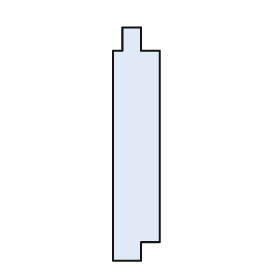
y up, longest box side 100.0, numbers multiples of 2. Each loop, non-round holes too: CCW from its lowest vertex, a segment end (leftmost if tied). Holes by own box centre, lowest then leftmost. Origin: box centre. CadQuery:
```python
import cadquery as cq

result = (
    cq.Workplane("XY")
    .moveTo(-10.0, -50.0)
    .lineTo(2.0, -50.0)
    .lineTo(2.0, -42.0)
    .lineTo(10.0, -42.0)
    .lineTo(10.0, 40.0)
    .lineTo(2.0, 40.0)
    .lineTo(2.0, 50.0)
    .lineTo(-6.0, 50.0)
    .lineTo(-6.0, 40.0)
    .lineTo(-10.0, 40.0)
    .close()
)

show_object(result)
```